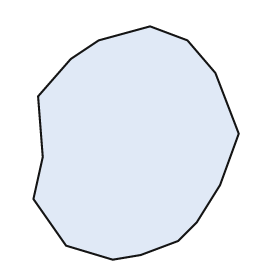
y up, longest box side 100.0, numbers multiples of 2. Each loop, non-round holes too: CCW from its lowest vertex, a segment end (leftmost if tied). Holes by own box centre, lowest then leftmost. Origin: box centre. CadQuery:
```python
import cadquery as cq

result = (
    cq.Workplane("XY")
    .moveTo(-10.0, -50.0)
    .lineTo(2.0, -48.0)
    .lineTo(18.0, -42.0)
    .lineTo(26.0, -34.0)
    .lineTo(36.0, -18.0)
    .lineTo(44.0, 4.0)
    .lineTo(34.0, 30.0)
    .lineTo(22.0, 44.0)
    .lineTo(6.0, 50.0)
    .lineTo(-16.0, 44.0)
    .lineTo(-28.0, 36.0)
    .lineTo(-42.0, 20.0)
    .lineTo(-40.0, -6.0)
    .lineTo(-44.0, -24.0)
    .lineTo(-30.0, -44.0)
    .close()
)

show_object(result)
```